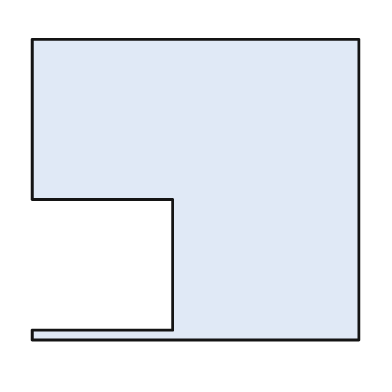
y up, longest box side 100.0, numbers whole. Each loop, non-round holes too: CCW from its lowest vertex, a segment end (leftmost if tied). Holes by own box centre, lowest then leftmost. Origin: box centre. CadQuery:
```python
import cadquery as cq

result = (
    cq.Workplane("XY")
    .moveTo(-50.0, -46.0)
    .lineTo(50.0, -46.0)
    .lineTo(50.0, 46.0)
    .lineTo(-50.0, 46.0)
    .lineTo(-50.0, -3.0)
    .lineTo(-7.0, -3.0)
    .lineTo(-7.0, -43.0)
    .lineTo(-50.0, -43.0)
    .close()
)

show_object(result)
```